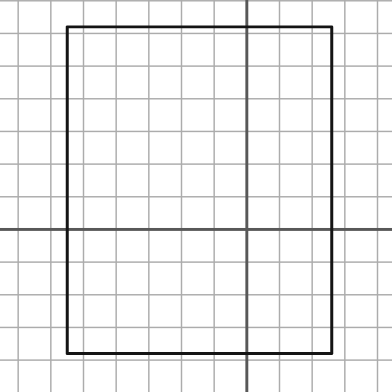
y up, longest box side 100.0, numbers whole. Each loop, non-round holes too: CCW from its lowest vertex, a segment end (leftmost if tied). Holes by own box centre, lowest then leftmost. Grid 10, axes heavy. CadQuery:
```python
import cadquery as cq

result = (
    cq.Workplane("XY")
    .moveTo(-55.0, -38.0)
    .lineTo(26.0, -38.0)
    .lineTo(26.0, 62.0)
    .lineTo(-55.0, 62.0)
    .close()
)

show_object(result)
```